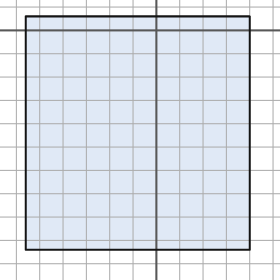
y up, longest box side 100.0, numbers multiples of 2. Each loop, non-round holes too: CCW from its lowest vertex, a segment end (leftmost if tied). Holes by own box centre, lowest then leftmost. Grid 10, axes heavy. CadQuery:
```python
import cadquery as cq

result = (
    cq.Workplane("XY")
    .moveTo(-56.0, -94.0)
    .lineTo(40.0, -94.0)
    .lineTo(40.0, 6.0)
    .lineTo(-56.0, 6.0)
    .close()
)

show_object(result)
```